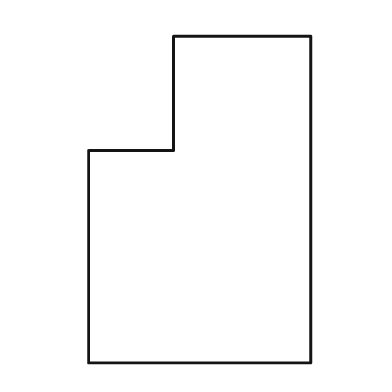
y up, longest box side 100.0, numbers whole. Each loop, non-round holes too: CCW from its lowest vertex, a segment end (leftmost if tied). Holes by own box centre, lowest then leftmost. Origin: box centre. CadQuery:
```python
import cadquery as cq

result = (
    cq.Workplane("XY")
    .moveTo(-34.0, -50.0)
    .lineTo(34.0, -50.0)
    .lineTo(34.0, 50.0)
    .lineTo(-8.0, 50.0)
    .lineTo(-8.0, 15.0)
    .lineTo(-34.0, 15.0)
    .close()
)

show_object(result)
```